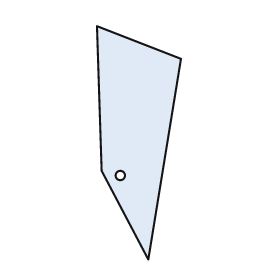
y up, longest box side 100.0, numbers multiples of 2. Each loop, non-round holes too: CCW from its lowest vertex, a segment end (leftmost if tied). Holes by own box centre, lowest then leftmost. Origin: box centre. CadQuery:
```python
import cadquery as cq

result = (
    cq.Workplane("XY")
    .moveTo(4.0, -50.0)
    .lineTo(18.0, 36.0)
    .lineTo(-18.0, 50.0)
    .lineTo(-16.0, -12.0)
    .close()
    .moveTo(-8.0, -14.0)
    .circle(2.0)
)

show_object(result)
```